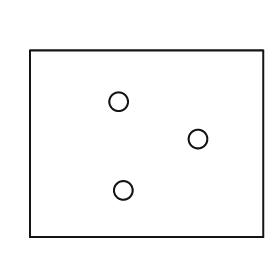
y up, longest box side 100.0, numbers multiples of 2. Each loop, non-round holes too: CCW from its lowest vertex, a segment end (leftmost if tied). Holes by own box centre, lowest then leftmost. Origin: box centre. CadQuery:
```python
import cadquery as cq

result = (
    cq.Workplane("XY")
    .moveTo(-50.0, -40.0)
    .lineTo(50.0, -40.0)
    .lineTo(50.0, 40.0)
    .lineTo(-50.0, 40.0)
    .close()
    .moveTo(-10.0, -20.0)
    .circle(4.0)
    .moveTo(22.0, 2.0)
    .circle(4.0)
    .moveTo(-12.0, 18.0)
    .circle(4.0)
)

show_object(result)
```